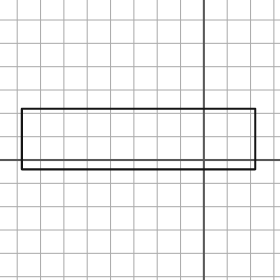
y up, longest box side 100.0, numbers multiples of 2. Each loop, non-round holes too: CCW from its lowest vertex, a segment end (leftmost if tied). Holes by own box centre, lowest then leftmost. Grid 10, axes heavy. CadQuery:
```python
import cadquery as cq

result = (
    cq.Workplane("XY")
    .moveTo(-78.0, -4.0)
    .lineTo(22.0, -4.0)
    .lineTo(22.0, 22.0)
    .lineTo(-78.0, 22.0)
    .close()
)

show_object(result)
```